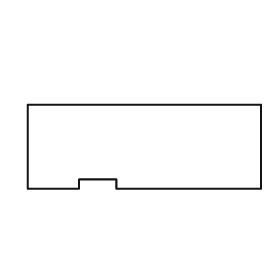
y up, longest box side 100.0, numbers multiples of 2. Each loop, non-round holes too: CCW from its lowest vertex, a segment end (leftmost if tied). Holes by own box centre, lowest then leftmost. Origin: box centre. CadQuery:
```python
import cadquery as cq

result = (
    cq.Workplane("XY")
    .moveTo(-50.0, -18.0)
    .lineTo(-28.0, -18.0)
    .lineTo(-28.0, -14.0)
    .lineTo(-12.0, -14.0)
    .lineTo(-12.0, -18.0)
    .lineTo(50.0, -18.0)
    .lineTo(50.0, 18.0)
    .lineTo(-50.0, 18.0)
    .close()
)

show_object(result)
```